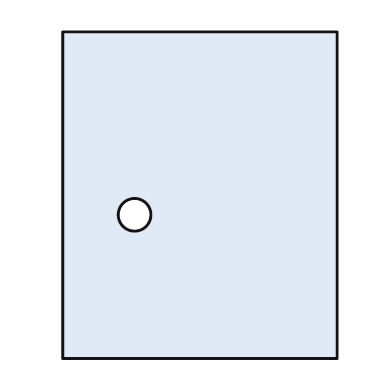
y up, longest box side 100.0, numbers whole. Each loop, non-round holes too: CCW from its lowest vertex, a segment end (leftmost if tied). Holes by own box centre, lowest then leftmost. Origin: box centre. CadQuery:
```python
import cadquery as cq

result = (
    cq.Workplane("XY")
    .moveTo(-42.0, -50.0)
    .lineTo(42.0, -50.0)
    .lineTo(42.0, 50.0)
    .lineTo(-42.0, 50.0)
    .close()
    .moveTo(-20.0, -6.0)
    .circle(5.0)
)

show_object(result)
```